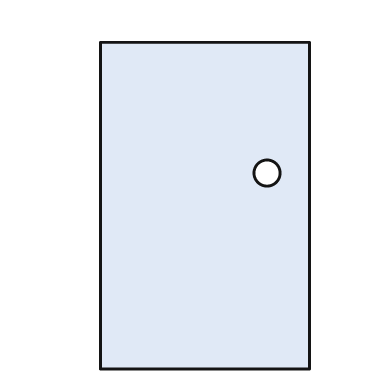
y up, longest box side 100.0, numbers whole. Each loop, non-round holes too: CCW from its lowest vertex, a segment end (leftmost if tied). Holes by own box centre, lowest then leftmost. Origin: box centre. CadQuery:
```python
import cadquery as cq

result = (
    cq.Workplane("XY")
    .moveTo(-32.0, -50.0)
    .lineTo(32.0, -50.0)
    .lineTo(32.0, 50.0)
    .lineTo(-32.0, 50.0)
    .close()
    .moveTo(19.0, 10.0)
    .circle(4.0)
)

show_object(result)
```